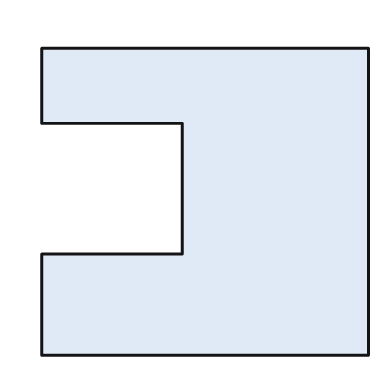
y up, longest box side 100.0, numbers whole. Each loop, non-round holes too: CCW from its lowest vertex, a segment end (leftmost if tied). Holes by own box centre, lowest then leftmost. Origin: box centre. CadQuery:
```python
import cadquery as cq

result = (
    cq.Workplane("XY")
    .moveTo(-50.0, -47.0)
    .lineTo(50.0, -47.0)
    .lineTo(50.0, 47.0)
    .lineTo(-50.0, 47.0)
    .lineTo(-50.0, 24.0)
    .lineTo(-7.0, 24.0)
    .lineTo(-7.0, -16.0)
    .lineTo(-50.0, -16.0)
    .close()
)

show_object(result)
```